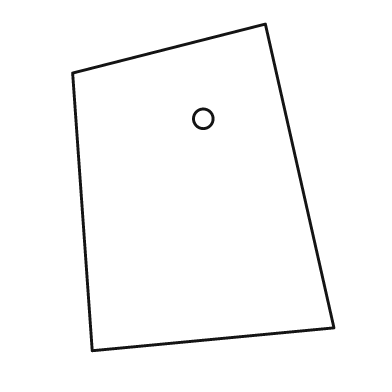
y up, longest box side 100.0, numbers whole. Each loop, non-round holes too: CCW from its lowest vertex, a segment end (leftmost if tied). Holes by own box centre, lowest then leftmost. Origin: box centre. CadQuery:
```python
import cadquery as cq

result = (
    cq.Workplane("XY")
    .moveTo(-34.0, -50.0)
    .lineTo(40.0, -43.0)
    .lineTo(19.0, 50.0)
    .lineTo(-40.0, 35.0)
    .close()
    .moveTo(0.0, 21.0)
    .circle(3.0)
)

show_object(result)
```